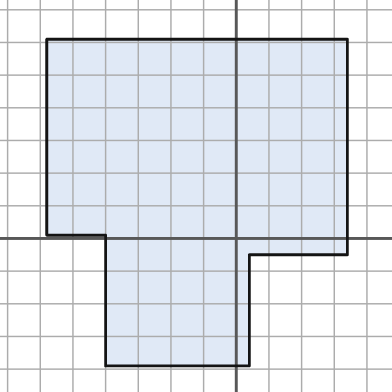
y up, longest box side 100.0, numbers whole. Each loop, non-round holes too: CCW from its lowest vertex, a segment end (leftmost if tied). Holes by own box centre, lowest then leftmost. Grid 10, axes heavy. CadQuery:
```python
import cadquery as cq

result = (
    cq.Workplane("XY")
    .moveTo(-40.0, -39.0)
    .lineTo(4.0, -39.0)
    .lineTo(4.0, -5.0)
    .lineTo(34.0, -5.0)
    .lineTo(34.0, 61.0)
    .lineTo(-58.0, 61.0)
    .lineTo(-58.0, 1.0)
    .lineTo(-40.0, 1.0)
    .close()
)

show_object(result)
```